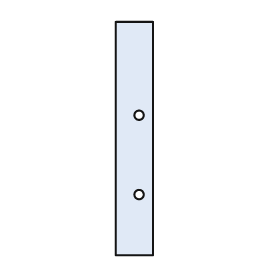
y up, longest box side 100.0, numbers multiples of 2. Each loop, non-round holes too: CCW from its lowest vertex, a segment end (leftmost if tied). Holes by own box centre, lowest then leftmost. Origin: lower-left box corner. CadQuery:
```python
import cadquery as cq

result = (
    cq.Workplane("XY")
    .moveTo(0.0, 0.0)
    .lineTo(16.0, 0.0)
    .lineTo(16.0, 100.0)
    .lineTo(0.0, 100.0)
    .close()
    .moveTo(10.0, 26.0)
    .circle(2.0)
    .moveTo(10.0, 60.0)
    .circle(2.0)
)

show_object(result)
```